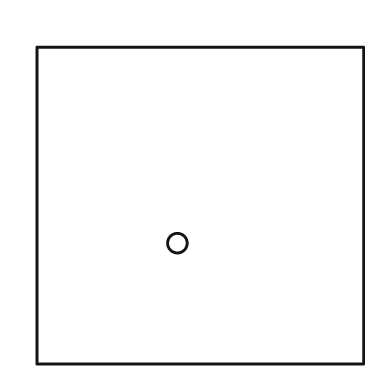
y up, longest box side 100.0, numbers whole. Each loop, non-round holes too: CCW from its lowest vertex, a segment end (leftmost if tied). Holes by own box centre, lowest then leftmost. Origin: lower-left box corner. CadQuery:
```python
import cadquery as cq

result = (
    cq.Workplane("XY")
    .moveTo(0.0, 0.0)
    .lineTo(100.0, 0.0)
    .lineTo(100.0, 97.0)
    .lineTo(0.0, 97.0)
    .close()
    .moveTo(43.0, 37.0)
    .circle(3.0)
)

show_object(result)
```